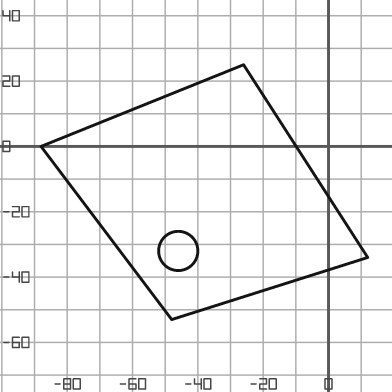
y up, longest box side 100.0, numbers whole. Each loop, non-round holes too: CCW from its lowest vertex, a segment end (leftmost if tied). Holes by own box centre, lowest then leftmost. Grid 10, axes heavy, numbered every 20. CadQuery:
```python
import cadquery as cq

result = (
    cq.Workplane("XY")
    .moveTo(-48.0, -53.0)
    .lineTo(12.0, -34.0)
    .lineTo(-26.0, 25.0)
    .lineTo(-88.0, 0.0)
    .close()
    .moveTo(-46.0, -32.0)
    .circle(6.0)
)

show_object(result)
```